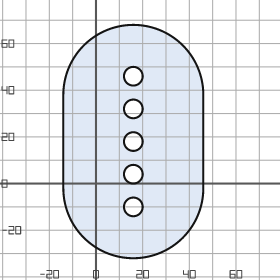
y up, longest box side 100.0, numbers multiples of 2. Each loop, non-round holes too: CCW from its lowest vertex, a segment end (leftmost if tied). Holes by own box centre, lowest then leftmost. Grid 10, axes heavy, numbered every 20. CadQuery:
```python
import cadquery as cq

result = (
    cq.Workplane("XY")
    .moveTo(-14.0, -2.0)
    .threePointArc((16.0, -32.0), (46.0, -2.0))
    .lineTo(46.0, 38.0)
    .threePointArc((16.0, 68.0), (-14.0, 38.0))
    .close()
    .moveTo(16.0, -10.0)
    .circle(4.0)
    .moveTo(16.0, 4.0)
    .circle(4.0)
    .moveTo(16.0, 18.0)
    .circle(4.0)
    .moveTo(16.0, 32.0)
    .circle(4.0)
    .moveTo(16.0, 46.0)
    .circle(4.0)
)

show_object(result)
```